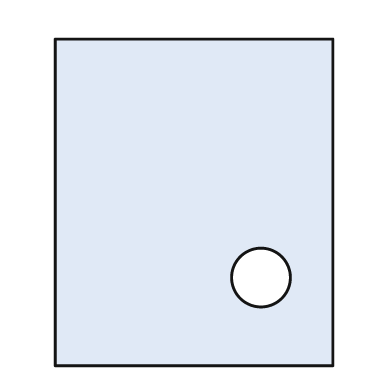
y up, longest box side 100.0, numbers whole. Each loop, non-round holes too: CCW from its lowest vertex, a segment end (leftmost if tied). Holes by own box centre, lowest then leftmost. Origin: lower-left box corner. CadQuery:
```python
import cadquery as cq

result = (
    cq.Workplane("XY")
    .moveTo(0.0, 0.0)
    .lineTo(85.0, 0.0)
    .lineTo(85.0, 100.0)
    .lineTo(0.0, 100.0)
    .close()
    .moveTo(63.0, 27.0)
    .circle(9.0)
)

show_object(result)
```